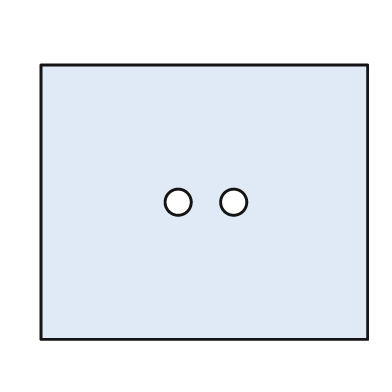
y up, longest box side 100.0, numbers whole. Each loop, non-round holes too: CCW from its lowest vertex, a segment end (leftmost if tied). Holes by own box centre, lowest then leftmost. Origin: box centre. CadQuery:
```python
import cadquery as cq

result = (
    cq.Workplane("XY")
    .moveTo(-50.0, -42.0)
    .lineTo(50.0, -42.0)
    .lineTo(50.0, 42.0)
    .lineTo(-50.0, 42.0)
    .close()
    .moveTo(-8.0, 0.0)
    .circle(4.0)
    .moveTo(9.0, 0.0)
    .circle(4.0)
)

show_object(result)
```